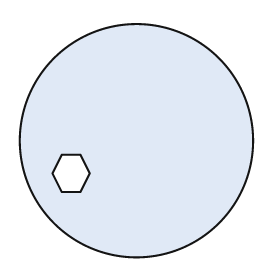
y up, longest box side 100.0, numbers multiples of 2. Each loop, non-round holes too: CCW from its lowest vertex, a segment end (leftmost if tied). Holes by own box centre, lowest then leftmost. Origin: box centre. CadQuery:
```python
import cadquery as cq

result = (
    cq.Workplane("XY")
    .moveTo(0.0, 0.0)
    .circle(50.0)
    .moveTo(-32.0, -22.0)
    .lineTo(-24.0, -22.0)
    .lineTo(-20.0, -14.0)
    .lineTo(-24.0, -6.0)
    .lineTo(-32.0, -6.0)
    .lineTo(-36.0, -14.0)
    .close()
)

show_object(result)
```